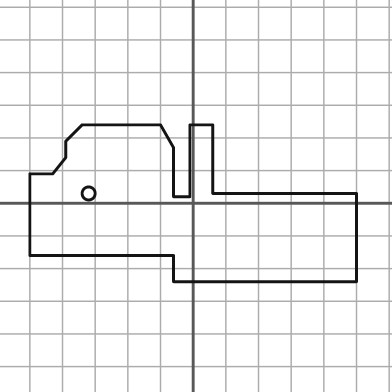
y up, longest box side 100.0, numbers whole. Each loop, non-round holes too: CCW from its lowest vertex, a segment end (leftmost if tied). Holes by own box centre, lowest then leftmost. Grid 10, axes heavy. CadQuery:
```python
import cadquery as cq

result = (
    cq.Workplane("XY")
    .moveTo(-6.0, -24.0)
    .lineTo(50.0, -24.0)
    .lineTo(50.0, 3.0)
    .lineTo(6.0, 3.0)
    .lineTo(6.0, 24.0)
    .lineTo(-1.0, 24.0)
    .lineTo(-1.0, 2.0)
    .lineTo(-6.0, 2.0)
    .lineTo(-6.0, 17.0)
    .lineTo(-10.0, 24.0)
    .lineTo(-34.0, 24.0)
    .lineTo(-39.0, 19.0)
    .lineTo(-39.0, 14.0)
    .lineTo(-43.0, 9.0)
    .lineTo(-50.0, 9.0)
    .lineTo(-50.0, -16.0)
    .lineTo(-6.0, -16.0)
    .close()
    .moveTo(-32.0, 3.0)
    .circle(2.0)
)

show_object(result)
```